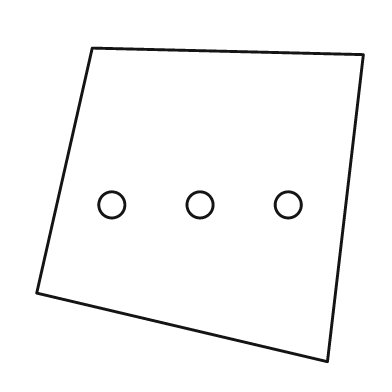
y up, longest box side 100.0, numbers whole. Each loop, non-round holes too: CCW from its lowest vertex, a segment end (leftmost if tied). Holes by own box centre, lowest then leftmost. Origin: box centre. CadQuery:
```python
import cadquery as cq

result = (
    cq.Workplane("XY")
    .moveTo(39.0, -48.0)
    .lineTo(50.0, 46.0)
    .lineTo(-33.0, 48.0)
    .lineTo(-50.0, -27.0)
    .close()
    .moveTo(-27.0, 0.0)
    .circle(4.0)
    .moveTo(0.0, 0.0)
    .circle(4.0)
    .moveTo(27.0, 0.0)
    .circle(4.0)
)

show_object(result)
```